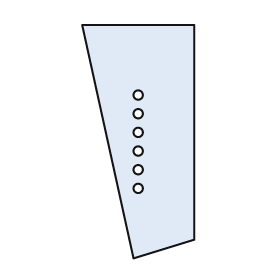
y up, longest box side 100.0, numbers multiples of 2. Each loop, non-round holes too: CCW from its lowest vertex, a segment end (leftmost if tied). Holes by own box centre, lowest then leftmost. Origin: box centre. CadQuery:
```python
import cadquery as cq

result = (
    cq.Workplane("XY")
    .moveTo(-2.0, -50.0)
    .lineTo(24.0, -42.0)
    .lineTo(24.0, 50.0)
    .lineTo(-24.0, 50.0)
    .close()
    .moveTo(0.0, -20.0)
    .circle(2.0)
    .moveTo(0.0, -12.0)
    .circle(2.0)
    .moveTo(0.0, -4.0)
    .circle(2.0)
    .moveTo(0.0, 4.0)
    .circle(2.0)
    .moveTo(0.0, 12.0)
    .circle(2.0)
    .moveTo(0.0, 20.0)
    .circle(2.0)
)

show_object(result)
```